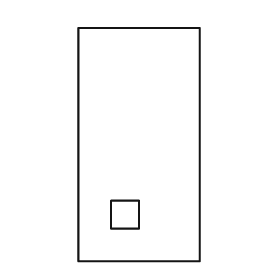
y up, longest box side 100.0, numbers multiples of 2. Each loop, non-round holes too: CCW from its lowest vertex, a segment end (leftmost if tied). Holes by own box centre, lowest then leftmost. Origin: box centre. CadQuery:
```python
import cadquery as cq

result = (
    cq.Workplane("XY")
    .moveTo(-26.0, -50.0)
    .lineTo(26.0, -50.0)
    .lineTo(26.0, 50.0)
    .lineTo(-26.0, 50.0)
    .close()
    .moveTo(-12.0, -36.0)
    .lineTo(0.0, -36.0)
    .lineTo(0.0, -24.0)
    .lineTo(-12.0, -24.0)
    .close()
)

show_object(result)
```